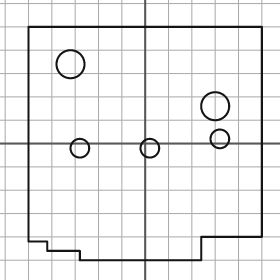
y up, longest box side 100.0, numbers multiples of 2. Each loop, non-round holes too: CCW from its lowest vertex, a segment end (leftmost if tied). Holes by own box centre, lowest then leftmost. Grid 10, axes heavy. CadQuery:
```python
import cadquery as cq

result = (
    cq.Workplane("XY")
    .moveTo(-28.0, -50.0)
    .lineTo(24.0, -50.0)
    .lineTo(24.0, -40.0)
    .lineTo(50.0, -40.0)
    .lineTo(50.0, 50.0)
    .lineTo(-50.0, 50.0)
    .lineTo(-50.0, -42.0)
    .lineTo(-42.0, -42.0)
    .lineTo(-42.0, -46.0)
    .lineTo(-28.0, -46.0)
    .close()
    .moveTo(-28.0, -2.0)
    .circle(4.0)
    .moveTo(2.0, -2.0)
    .circle(4.0)
    .moveTo(32.0, 2.0)
    .circle(4.0)
    .moveTo(30.0, 16.0)
    .circle(6.0)
    .moveTo(-32.0, 34.0)
    .circle(6.0)
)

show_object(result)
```